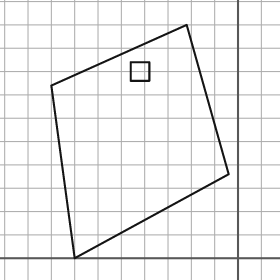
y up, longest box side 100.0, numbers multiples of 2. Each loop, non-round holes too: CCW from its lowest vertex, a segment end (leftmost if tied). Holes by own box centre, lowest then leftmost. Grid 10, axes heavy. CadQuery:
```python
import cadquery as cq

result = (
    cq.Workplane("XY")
    .moveTo(-70.0, 0.0)
    .lineTo(-4.0, 36.0)
    .lineTo(-22.0, 100.0)
    .lineTo(-80.0, 74.0)
    .close()
    .moveTo(-46.0, 76.0)
    .lineTo(-38.0, 76.0)
    .lineTo(-38.0, 84.0)
    .lineTo(-46.0, 84.0)
    .close()
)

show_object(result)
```